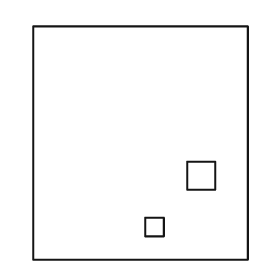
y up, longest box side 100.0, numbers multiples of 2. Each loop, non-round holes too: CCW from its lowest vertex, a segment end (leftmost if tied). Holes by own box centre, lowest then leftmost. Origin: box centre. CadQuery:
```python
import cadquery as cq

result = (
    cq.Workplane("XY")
    .moveTo(-46.0, -50.0)
    .lineTo(46.0, -50.0)
    .lineTo(46.0, 50.0)
    .lineTo(-46.0, 50.0)
    .close()
    .moveTo(2.0, -40.0)
    .lineTo(10.0, -40.0)
    .lineTo(10.0, -32.0)
    .lineTo(2.0, -32.0)
    .close()
    .moveTo(20.0, -20.0)
    .lineTo(32.0, -20.0)
    .lineTo(32.0, -8.0)
    .lineTo(20.0, -8.0)
    .close()
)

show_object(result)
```